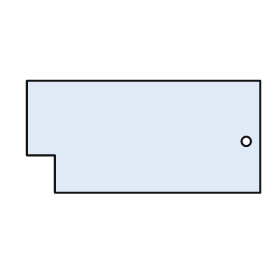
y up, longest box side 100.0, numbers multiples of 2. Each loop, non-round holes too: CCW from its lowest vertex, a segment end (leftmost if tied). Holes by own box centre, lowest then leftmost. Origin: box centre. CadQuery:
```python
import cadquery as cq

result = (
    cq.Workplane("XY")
    .moveTo(-38.0, -24.0)
    .lineTo(50.0, -24.0)
    .lineTo(50.0, 24.0)
    .lineTo(-50.0, 24.0)
    .lineTo(-50.0, -8.0)
    .lineTo(-38.0, -8.0)
    .close()
    .moveTo(44.0, -2.0)
    .circle(2.0)
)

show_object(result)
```